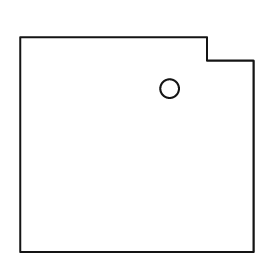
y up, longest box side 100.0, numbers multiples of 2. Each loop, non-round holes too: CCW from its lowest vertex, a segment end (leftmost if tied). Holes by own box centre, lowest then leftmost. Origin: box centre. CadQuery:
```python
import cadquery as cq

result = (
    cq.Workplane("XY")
    .moveTo(-50.0, -46.0)
    .lineTo(50.0, -46.0)
    .lineTo(50.0, 36.0)
    .lineTo(30.0, 36.0)
    .lineTo(30.0, 46.0)
    .lineTo(-50.0, 46.0)
    .close()
    .moveTo(14.0, 24.0)
    .circle(4.0)
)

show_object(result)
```